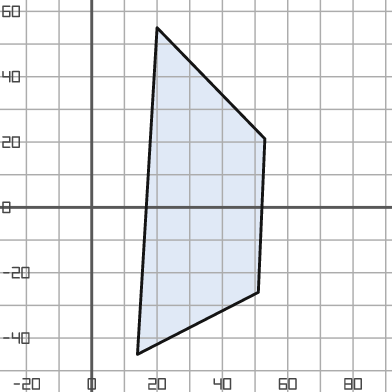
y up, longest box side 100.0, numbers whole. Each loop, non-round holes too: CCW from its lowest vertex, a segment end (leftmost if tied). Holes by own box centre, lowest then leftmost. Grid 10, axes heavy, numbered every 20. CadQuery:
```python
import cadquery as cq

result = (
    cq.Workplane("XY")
    .moveTo(14.0, -45.0)
    .lineTo(51.0, -26.0)
    .lineTo(53.0, 21.0)
    .lineTo(20.0, 55.0)
    .close()
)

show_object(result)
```